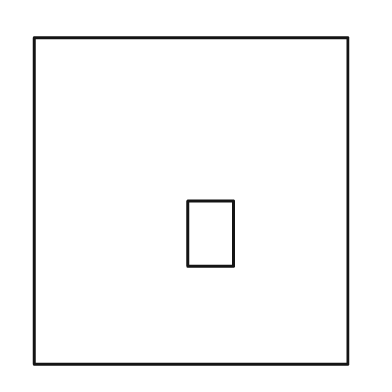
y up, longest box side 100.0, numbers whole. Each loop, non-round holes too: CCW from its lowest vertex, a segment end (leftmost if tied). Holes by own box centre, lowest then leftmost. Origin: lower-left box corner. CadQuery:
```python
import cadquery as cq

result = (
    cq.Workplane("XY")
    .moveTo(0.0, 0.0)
    .lineTo(96.0, 0.0)
    .lineTo(96.0, 100.0)
    .lineTo(0.0, 100.0)
    .close()
    .moveTo(47.0, 30.0)
    .lineTo(61.0, 30.0)
    .lineTo(61.0, 50.0)
    .lineTo(47.0, 50.0)
    .close()
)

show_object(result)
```